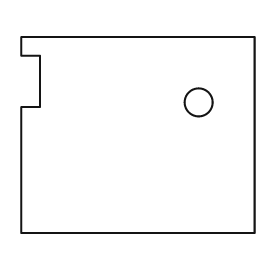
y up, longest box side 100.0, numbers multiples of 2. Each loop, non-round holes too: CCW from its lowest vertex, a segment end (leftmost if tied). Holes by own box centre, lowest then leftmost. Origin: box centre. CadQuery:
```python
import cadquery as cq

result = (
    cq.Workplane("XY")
    .moveTo(-50.0, -42.0)
    .lineTo(50.0, -42.0)
    .lineTo(50.0, 42.0)
    .lineTo(-50.0, 42.0)
    .lineTo(-50.0, 34.0)
    .lineTo(-42.0, 34.0)
    .lineTo(-42.0, 12.0)
    .lineTo(-50.0, 12.0)
    .close()
    .moveTo(26.0, 14.0)
    .circle(6.0)
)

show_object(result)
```